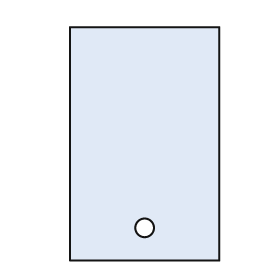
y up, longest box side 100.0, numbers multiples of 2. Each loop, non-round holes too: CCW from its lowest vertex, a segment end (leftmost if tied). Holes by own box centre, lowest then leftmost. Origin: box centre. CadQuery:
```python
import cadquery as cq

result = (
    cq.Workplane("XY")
    .moveTo(-32.0, -50.0)
    .lineTo(32.0, -50.0)
    .lineTo(32.0, 50.0)
    .lineTo(-32.0, 50.0)
    .close()
    .moveTo(0.0, -36.0)
    .circle(4.0)
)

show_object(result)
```